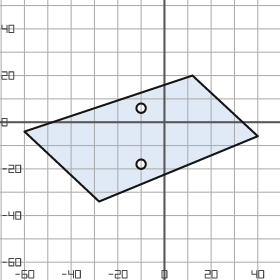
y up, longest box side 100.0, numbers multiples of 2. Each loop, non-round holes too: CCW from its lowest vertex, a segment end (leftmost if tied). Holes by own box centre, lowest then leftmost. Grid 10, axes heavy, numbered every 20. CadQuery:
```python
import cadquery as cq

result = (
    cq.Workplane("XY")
    .moveTo(-28.0, -34.0)
    .lineTo(40.0, -6.0)
    .lineTo(12.0, 20.0)
    .lineTo(-60.0, -4.0)
    .close()
    .moveTo(-10.0, -18.0)
    .circle(2.0)
    .moveTo(-10.0, 6.0)
    .circle(2.0)
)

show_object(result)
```